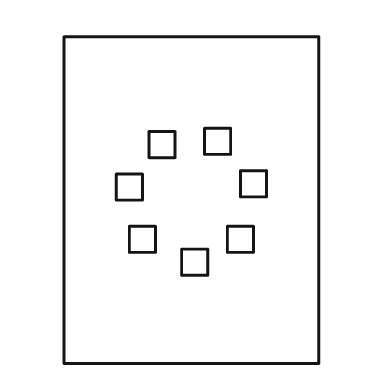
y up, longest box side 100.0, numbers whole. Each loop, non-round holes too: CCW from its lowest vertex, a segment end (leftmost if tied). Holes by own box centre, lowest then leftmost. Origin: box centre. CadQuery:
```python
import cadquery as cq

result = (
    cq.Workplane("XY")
    .moveTo(-39.0, -50.0)
    .lineTo(39.0, -50.0)
    .lineTo(39.0, 50.0)
    .lineTo(-39.0, 50.0)
    .close()
    .moveTo(-3.0, -23.0)
    .lineTo(5.0, -23.0)
    .lineTo(5.0, -15.0)
    .lineTo(-3.0, -15.0)
    .close()
    .moveTo(-19.0, -16.0)
    .lineTo(-11.0, -16.0)
    .lineTo(-11.0, -8.0)
    .lineTo(-19.0, -8.0)
    .close()
    .moveTo(11.0, -16.0)
    .lineTo(19.0, -16.0)
    .lineTo(19.0, -8.0)
    .lineTo(11.0, -8.0)
    .close()
    .moveTo(-23.0, 0.0)
    .lineTo(-15.0, 0.0)
    .lineTo(-15.0, 8.0)
    .lineTo(-23.0, 8.0)
    .close()
    .moveTo(15.0, 1.0)
    .lineTo(23.0, 1.0)
    .lineTo(23.0, 9.0)
    .lineTo(15.0, 9.0)
    .close()
    .moveTo(-13.0, 13.0)
    .lineTo(-5.0, 13.0)
    .lineTo(-5.0, 21.0)
    .lineTo(-13.0, 21.0)
    .close()
    .moveTo(4.0, 14.0)
    .lineTo(12.0, 14.0)
    .lineTo(12.0, 22.0)
    .lineTo(4.0, 22.0)
    .close()
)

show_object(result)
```